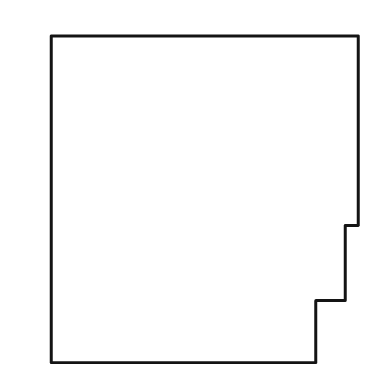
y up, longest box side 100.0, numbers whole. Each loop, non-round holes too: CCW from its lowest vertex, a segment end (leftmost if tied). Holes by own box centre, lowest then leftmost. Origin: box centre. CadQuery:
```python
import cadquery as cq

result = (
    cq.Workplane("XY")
    .moveTo(-47.0, -50.0)
    .lineTo(34.0, -50.0)
    .lineTo(34.0, -31.0)
    .lineTo(43.0, -31.0)
    .lineTo(43.0, -8.0)
    .lineTo(47.0, -8.0)
    .lineTo(47.0, 50.0)
    .lineTo(-47.0, 50.0)
    .close()
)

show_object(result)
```